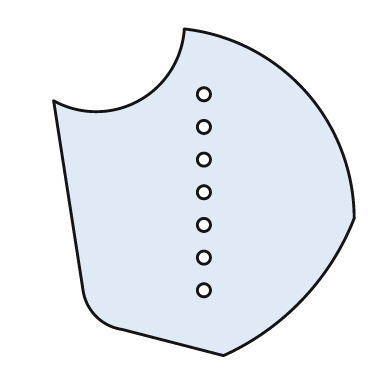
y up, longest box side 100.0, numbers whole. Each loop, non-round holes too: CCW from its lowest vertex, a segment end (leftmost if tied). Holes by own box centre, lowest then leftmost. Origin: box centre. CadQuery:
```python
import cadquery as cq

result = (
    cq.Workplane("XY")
    .moveTo(6.0, -50.0)
    .threePointArc((30.0, -33.0), (46.0, -8.0))
    .threePointArc((31.0, 31.0), (-6.0, 50.0))
    .threePointArc((-20.0, 28.0), (-46.0, 28.0))
    .lineTo(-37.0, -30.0)
    .threePointArc((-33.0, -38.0), (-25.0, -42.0))
    .close()
    .moveTo(0.0, -30.0)
    .circle(2.0)
    .moveTo(0.0, -20.0)
    .circle(2.0)
    .moveTo(0.0, -10.0)
    .circle(2.0)
    .moveTo(0.0, 0.0)
    .circle(2.0)
    .moveTo(0.0, 10.0)
    .circle(2.0)
    .moveTo(0.0, 20.0)
    .circle(2.0)
    .moveTo(0.0, 30.0)
    .circle(2.0)
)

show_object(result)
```